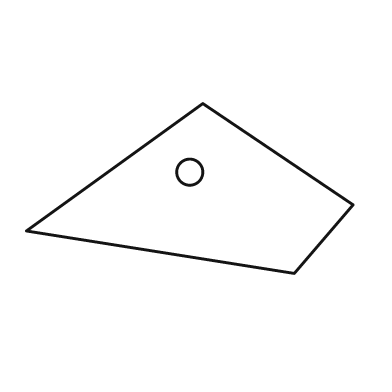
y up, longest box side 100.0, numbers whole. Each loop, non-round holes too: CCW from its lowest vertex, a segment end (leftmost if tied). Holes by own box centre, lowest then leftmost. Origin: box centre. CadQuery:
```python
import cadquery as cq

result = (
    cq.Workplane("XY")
    .moveTo(32.0, -26.0)
    .lineTo(50.0, -5.0)
    .lineTo(4.0, 26.0)
    .lineTo(-50.0, -13.0)
    .close()
    .moveTo(0.0, 5.0)
    .circle(4.0)
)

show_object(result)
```